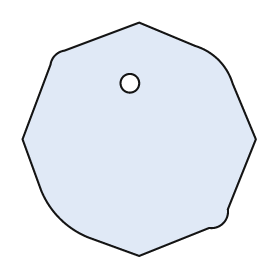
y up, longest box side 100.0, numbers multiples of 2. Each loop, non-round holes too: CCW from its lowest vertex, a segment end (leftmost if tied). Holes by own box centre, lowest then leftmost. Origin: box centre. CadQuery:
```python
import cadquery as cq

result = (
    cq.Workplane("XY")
    .moveTo(0.0, -50.0)
    .lineTo(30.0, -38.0)
    .threePointArc((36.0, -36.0), (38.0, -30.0))
    .lineTo(50.0, 0.0)
    .lineTo(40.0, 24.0)
    .threePointArc((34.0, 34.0), (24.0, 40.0))
    .lineTo(0.0, 50.0)
    .lineTo(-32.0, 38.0)
    .threePointArc((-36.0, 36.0), (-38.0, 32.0))
    .lineTo(-50.0, 0.0)
    .lineTo(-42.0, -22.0)
    .threePointArc((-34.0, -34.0), (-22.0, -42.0))
    .close()
    .moveTo(-4.0, 24.0)
    .circle(4.0)
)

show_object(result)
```